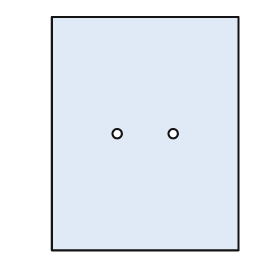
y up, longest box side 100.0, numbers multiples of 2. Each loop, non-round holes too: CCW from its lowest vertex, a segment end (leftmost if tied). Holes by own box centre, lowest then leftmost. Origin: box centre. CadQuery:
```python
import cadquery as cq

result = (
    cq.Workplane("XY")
    .moveTo(-40.0, -50.0)
    .lineTo(40.0, -50.0)
    .lineTo(40.0, 50.0)
    .lineTo(-40.0, 50.0)
    .close()
    .moveTo(-12.0, 0.0)
    .circle(2.0)
    .moveTo(12.0, 0.0)
    .circle(2.0)
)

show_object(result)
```